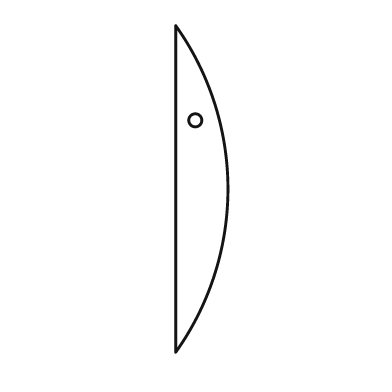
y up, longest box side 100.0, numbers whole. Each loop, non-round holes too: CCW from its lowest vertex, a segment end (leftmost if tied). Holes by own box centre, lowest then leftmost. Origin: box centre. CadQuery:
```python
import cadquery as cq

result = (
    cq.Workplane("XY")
    .moveTo(-8.0, -50.0)
    .threePointArc((8.0, 0.0), (-8.0, 50.0))
    .close()
    .moveTo(-2.0, 21.0)
    .circle(2.0)
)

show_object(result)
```